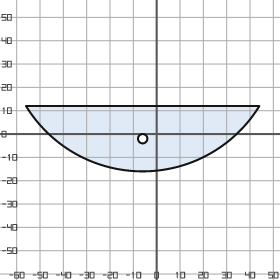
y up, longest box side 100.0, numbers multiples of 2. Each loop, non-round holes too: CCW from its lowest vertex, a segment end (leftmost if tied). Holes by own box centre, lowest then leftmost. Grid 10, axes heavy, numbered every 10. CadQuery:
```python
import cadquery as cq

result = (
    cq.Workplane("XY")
    .moveTo(-56.0, 12.0)
    .threePointArc((-6.0, -16.0), (44.0, 12.0))
    .close()
    .moveTo(-6.0, -2.0)
    .circle(2.0)
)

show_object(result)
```